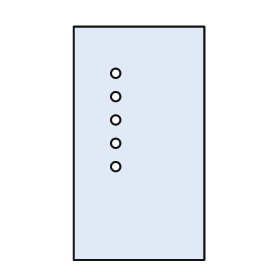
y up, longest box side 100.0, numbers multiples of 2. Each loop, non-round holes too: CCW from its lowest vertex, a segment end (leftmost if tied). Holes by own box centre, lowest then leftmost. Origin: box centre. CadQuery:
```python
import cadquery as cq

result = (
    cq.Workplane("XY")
    .moveTo(-28.0, -50.0)
    .lineTo(28.0, -50.0)
    .lineTo(28.0, 50.0)
    .lineTo(-28.0, 50.0)
    .close()
    .moveTo(-10.0, -10.0)
    .circle(2.0)
    .moveTo(-10.0, 0.0)
    .circle(2.0)
    .moveTo(-10.0, 10.0)
    .circle(2.0)
    .moveTo(-10.0, 20.0)
    .circle(2.0)
    .moveTo(-10.0, 30.0)
    .circle(2.0)
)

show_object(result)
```